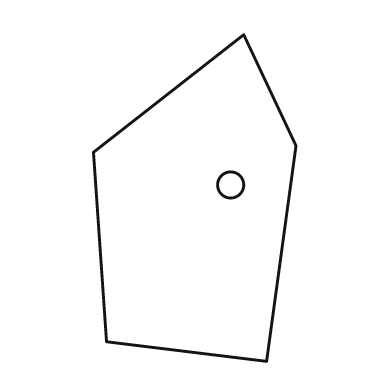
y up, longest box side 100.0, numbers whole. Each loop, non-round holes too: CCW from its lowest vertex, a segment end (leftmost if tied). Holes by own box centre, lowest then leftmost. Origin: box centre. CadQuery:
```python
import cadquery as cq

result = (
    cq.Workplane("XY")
    .moveTo(22.0, -50.0)
    .lineTo(31.0, 16.0)
    .lineTo(15.0, 50.0)
    .lineTo(-31.0, 14.0)
    .lineTo(-27.0, -44.0)
    .close()
    .moveTo(11.0, 4.0)
    .circle(4.0)
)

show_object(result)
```